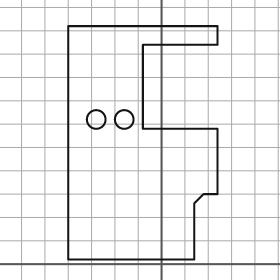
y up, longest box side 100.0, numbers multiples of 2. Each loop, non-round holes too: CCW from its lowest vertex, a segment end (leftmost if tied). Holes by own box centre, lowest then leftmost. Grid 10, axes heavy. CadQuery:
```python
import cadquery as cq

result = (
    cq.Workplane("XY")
    .moveTo(-40.0, 2.0)
    .lineTo(14.0, 2.0)
    .lineTo(14.0, 26.0)
    .lineTo(18.0, 30.0)
    .lineTo(24.0, 30.0)
    .lineTo(24.0, 58.0)
    .lineTo(-8.0, 58.0)
    .lineTo(-8.0, 94.0)
    .lineTo(24.0, 94.0)
    .lineTo(24.0, 102.0)
    .lineTo(-40.0, 102.0)
    .close()
    .moveTo(-28.0, 62.0)
    .circle(4.0)
    .moveTo(-16.0, 62.0)
    .circle(4.0)
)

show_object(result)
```